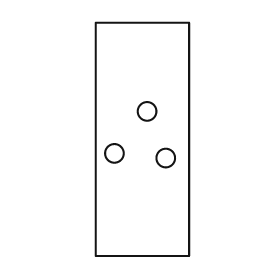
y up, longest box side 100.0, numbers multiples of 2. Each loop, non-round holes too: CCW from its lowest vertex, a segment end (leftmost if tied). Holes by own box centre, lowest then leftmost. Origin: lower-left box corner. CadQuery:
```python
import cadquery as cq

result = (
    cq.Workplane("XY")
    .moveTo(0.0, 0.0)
    .lineTo(40.0, 0.0)
    .lineTo(40.0, 100.0)
    .lineTo(0.0, 100.0)
    .close()
    .moveTo(30.0, 42.0)
    .circle(4.0)
    .moveTo(8.0, 44.0)
    .circle(4.0)
    .moveTo(22.0, 62.0)
    .circle(4.0)
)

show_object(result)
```